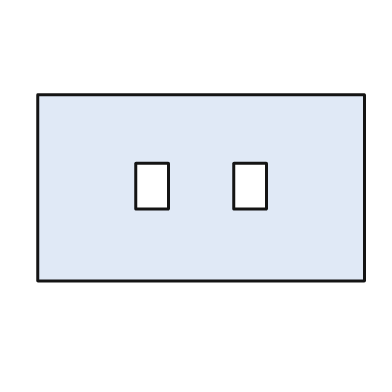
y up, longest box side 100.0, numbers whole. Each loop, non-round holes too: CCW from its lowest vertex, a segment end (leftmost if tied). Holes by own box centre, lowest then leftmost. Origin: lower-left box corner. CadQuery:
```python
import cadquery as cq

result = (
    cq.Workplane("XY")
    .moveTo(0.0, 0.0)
    .lineTo(100.0, 0.0)
    .lineTo(100.0, 57.0)
    .lineTo(0.0, 57.0)
    .close()
    .moveTo(30.0, 22.0)
    .lineTo(40.0, 22.0)
    .lineTo(40.0, 36.0)
    .lineTo(30.0, 36.0)
    .close()
    .moveTo(60.0, 22.0)
    .lineTo(70.0, 22.0)
    .lineTo(70.0, 36.0)
    .lineTo(60.0, 36.0)
    .close()
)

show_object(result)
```